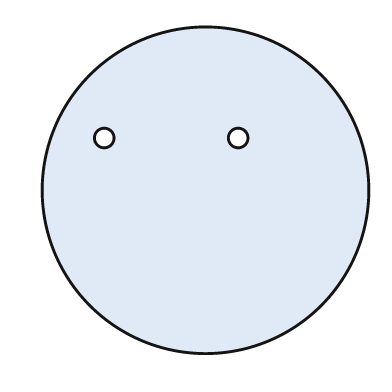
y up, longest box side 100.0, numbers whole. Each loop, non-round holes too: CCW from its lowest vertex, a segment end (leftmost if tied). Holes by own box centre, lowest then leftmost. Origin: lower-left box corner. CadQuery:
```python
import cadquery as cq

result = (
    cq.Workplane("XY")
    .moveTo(50.0, 50.0)
    .circle(50.0)
    .moveTo(19.0, 66.0)
    .circle(3.0)
    .moveTo(60.0, 66.0)
    .circle(3.0)
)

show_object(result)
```